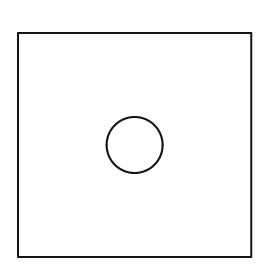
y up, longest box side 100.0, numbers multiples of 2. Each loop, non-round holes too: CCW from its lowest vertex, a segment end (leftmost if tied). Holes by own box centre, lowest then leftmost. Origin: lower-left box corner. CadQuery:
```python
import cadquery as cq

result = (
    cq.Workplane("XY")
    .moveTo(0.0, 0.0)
    .lineTo(100.0, 0.0)
    .lineTo(100.0, 96.0)
    .lineTo(0.0, 96.0)
    .close()
    .moveTo(50.0, 48.0)
    .circle(12.0)
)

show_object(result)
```